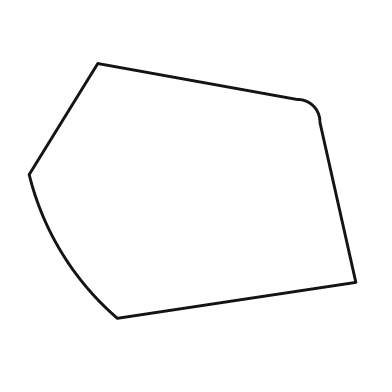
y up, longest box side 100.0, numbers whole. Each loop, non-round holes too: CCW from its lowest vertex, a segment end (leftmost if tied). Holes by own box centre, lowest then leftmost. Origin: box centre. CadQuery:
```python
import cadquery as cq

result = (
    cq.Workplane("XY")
    .moveTo(-23.0, -39.0)
    .lineTo(50.0, -28.0)
    .lineTo(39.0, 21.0)
    .threePointArc((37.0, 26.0), (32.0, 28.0))
    .lineTo(-29.0, 39.0)
    .lineTo(-50.0, 5.0)
    .threePointArc((-40.0, -19.0), (-23.0, -39.0))
    .close()
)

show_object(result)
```